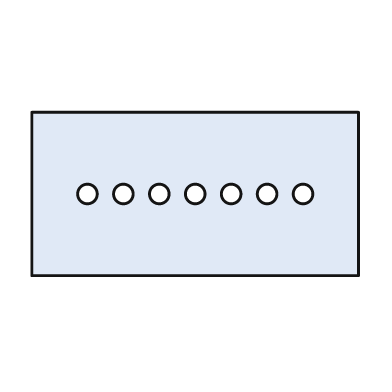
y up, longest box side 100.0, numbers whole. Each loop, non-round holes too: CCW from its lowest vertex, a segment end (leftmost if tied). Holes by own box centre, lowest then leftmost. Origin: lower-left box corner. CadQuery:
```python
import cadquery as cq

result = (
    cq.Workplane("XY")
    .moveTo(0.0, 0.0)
    .lineTo(100.0, 0.0)
    .lineTo(100.0, 50.0)
    .lineTo(0.0, 50.0)
    .close()
    .moveTo(17.0, 25.0)
    .circle(3.0)
    .moveTo(28.0, 25.0)
    .circle(3.0)
    .moveTo(39.0, 25.0)
    .circle(3.0)
    .moveTo(50.0, 25.0)
    .circle(3.0)
    .moveTo(61.0, 25.0)
    .circle(3.0)
    .moveTo(72.0, 25.0)
    .circle(3.0)
    .moveTo(83.0, 25.0)
    .circle(3.0)
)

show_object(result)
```